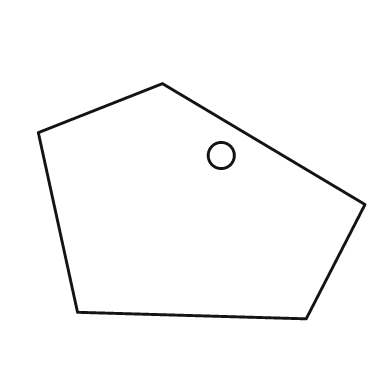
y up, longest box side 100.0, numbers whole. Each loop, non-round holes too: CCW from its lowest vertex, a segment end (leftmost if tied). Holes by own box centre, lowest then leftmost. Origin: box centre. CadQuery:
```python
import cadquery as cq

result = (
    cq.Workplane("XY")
    .moveTo(32.0, -36.0)
    .lineTo(50.0, -1.0)
    .lineTo(-12.0, 36.0)
    .lineTo(-50.0, 21.0)
    .lineTo(-38.0, -34.0)
    .close()
    .moveTo(6.0, 14.0)
    .circle(4.0)
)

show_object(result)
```